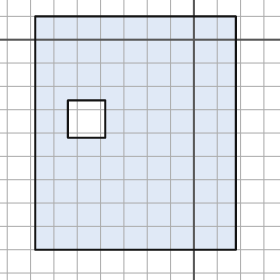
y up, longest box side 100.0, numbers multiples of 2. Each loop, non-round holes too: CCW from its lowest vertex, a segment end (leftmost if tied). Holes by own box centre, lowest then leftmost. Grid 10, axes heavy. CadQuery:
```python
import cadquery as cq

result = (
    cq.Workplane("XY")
    .moveTo(-68.0, -90.0)
    .lineTo(18.0, -90.0)
    .lineTo(18.0, 10.0)
    .lineTo(-68.0, 10.0)
    .close()
    .moveTo(-54.0, -42.0)
    .lineTo(-38.0, -42.0)
    .lineTo(-38.0, -26.0)
    .lineTo(-54.0, -26.0)
    .close()
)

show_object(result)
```